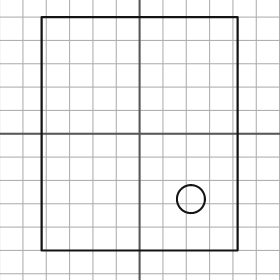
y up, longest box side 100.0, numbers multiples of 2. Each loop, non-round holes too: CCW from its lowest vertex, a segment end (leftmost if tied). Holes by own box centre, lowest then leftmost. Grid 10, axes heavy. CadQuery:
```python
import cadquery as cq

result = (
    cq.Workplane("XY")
    .moveTo(-42.0, -50.0)
    .lineTo(42.0, -50.0)
    .lineTo(42.0, 50.0)
    .lineTo(-42.0, 50.0)
    .close()
    .moveTo(22.0, -28.0)
    .circle(6.0)
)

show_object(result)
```